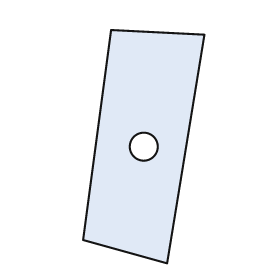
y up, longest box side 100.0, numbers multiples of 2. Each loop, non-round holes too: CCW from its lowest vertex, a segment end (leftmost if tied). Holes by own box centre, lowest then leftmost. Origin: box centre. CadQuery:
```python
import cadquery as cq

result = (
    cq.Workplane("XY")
    .moveTo(10.0, -50.0)
    .lineTo(26.0, 48.0)
    .lineTo(-14.0, 50.0)
    .lineTo(-26.0, -40.0)
    .close()
    .moveTo(0.0, 0.0)
    .circle(6.0)
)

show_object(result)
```